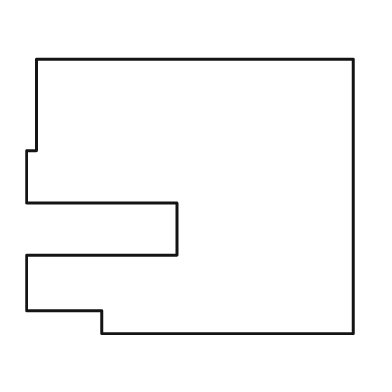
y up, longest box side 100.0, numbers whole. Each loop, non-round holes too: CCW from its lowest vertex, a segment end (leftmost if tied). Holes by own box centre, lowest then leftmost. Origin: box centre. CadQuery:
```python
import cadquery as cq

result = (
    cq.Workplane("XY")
    .moveTo(-27.0, -42.0)
    .lineTo(50.0, -42.0)
    .lineTo(50.0, 42.0)
    .lineTo(-47.0, 42.0)
    .lineTo(-47.0, 14.0)
    .lineTo(-50.0, 14.0)
    .lineTo(-50.0, -2.0)
    .lineTo(-4.0, -2.0)
    .lineTo(-4.0, -18.0)
    .lineTo(-50.0, -18.0)
    .lineTo(-50.0, -35.0)
    .lineTo(-27.0, -35.0)
    .close()
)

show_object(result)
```